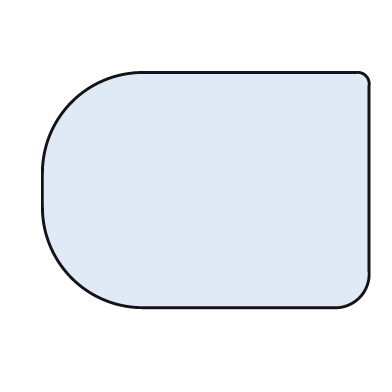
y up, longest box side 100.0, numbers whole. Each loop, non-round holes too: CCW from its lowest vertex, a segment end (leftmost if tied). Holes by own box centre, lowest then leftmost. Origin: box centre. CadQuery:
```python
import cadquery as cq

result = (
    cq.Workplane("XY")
    .moveTo(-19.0, -36.0)
    .lineTo(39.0, -36.0)
    .threePointArc((47.0, -33.0), (50.0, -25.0))
    .lineTo(50.0, 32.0)
    .threePointArc((49.0, 35.0), (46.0, 36.0))
    .lineTo(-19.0, 36.0)
    .threePointArc((-41.0, 27.0), (-50.0, 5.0))
    .lineTo(-50.0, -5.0)
    .threePointArc((-41.0, -27.0), (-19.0, -36.0))
    .close()
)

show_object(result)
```